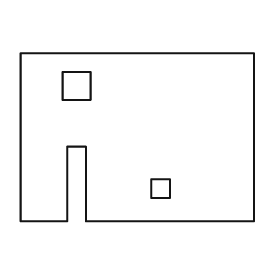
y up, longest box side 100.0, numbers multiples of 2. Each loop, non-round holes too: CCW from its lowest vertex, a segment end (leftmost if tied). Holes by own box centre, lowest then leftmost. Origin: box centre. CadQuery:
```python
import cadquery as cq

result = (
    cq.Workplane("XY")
    .moveTo(-50.0, -36.0)
    .lineTo(-30.0, -36.0)
    .lineTo(-30.0, -4.0)
    .lineTo(-22.0, -4.0)
    .lineTo(-22.0, -36.0)
    .lineTo(50.0, -36.0)
    .lineTo(50.0, 36.0)
    .lineTo(-50.0, 36.0)
    .close()
    .moveTo(6.0, -26.0)
    .lineTo(14.0, -26.0)
    .lineTo(14.0, -18.0)
    .lineTo(6.0, -18.0)
    .close()
    .moveTo(-32.0, 16.0)
    .lineTo(-20.0, 16.0)
    .lineTo(-20.0, 28.0)
    .lineTo(-32.0, 28.0)
    .close()
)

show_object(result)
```